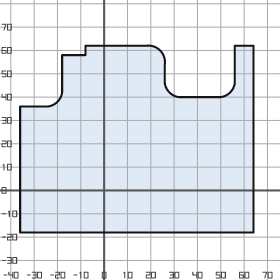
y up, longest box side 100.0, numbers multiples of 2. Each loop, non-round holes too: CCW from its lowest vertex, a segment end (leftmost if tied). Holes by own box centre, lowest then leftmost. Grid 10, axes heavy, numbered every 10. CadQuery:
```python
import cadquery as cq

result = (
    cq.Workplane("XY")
    .moveTo(-36.0, -18.0)
    .lineTo(64.0, -18.0)
    .lineTo(64.0, 62.0)
    .lineTo(56.0, 62.0)
    .lineTo(56.0, 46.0)
    .threePointArc((54.0, 42.0), (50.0, 40.0))
    .lineTo(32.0, 40.0)
    .threePointArc((28.0, 42.0), (26.0, 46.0))
    .lineTo(26.0, 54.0)
    .threePointArc((24.0, 60.0), (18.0, 62.0))
    .lineTo(-8.0, 62.0)
    .lineTo(-8.0, 58.0)
    .lineTo(-18.0, 58.0)
    .lineTo(-18.0, 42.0)
    .threePointArc((-20.0, 38.0), (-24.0, 36.0))
    .lineTo(-36.0, 36.0)
    .close()
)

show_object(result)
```